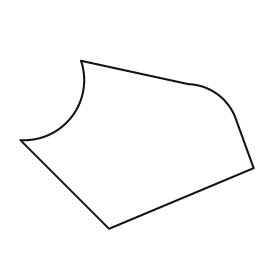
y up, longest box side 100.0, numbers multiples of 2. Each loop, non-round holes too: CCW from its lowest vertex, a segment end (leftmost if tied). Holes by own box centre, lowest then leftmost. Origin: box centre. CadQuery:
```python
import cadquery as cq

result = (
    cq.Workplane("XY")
    .moveTo(-12.0, -36.0)
    .lineTo(50.0, -10.0)
    .lineTo(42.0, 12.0)
    .threePointArc((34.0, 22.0), (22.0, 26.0))
    .lineTo(-24.0, 36.0)
    .threePointArc((-28.0, 12.0), (-50.0, 2.0))
    .close()
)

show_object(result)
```